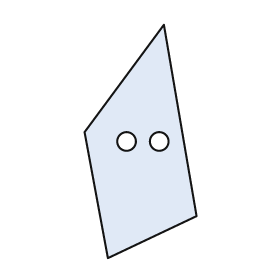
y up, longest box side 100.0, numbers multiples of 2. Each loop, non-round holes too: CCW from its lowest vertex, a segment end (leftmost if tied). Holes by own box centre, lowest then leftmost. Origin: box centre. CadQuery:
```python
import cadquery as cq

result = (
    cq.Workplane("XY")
    .moveTo(-14.0, -50.0)
    .lineTo(24.0, -32.0)
    .lineTo(10.0, 50.0)
    .lineTo(-24.0, 4.0)
    .close()
    .moveTo(-6.0, 0.0)
    .circle(4.0)
    .moveTo(8.0, 0.0)
    .circle(4.0)
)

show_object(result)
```